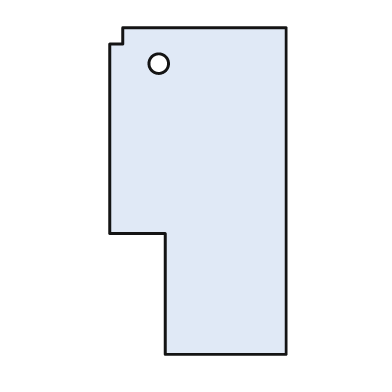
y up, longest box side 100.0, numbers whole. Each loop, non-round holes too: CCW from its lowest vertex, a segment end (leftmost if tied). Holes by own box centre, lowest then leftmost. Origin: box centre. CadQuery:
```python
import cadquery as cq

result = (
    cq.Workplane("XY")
    .moveTo(-10.0, -50.0)
    .lineTo(27.0, -50.0)
    .lineTo(27.0, 50.0)
    .lineTo(-23.0, 50.0)
    .lineTo(-23.0, 45.0)
    .lineTo(-27.0, 45.0)
    .lineTo(-27.0, -13.0)
    .lineTo(-10.0, -13.0)
    .close()
    .moveTo(-12.0, 39.0)
    .circle(3.0)
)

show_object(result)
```